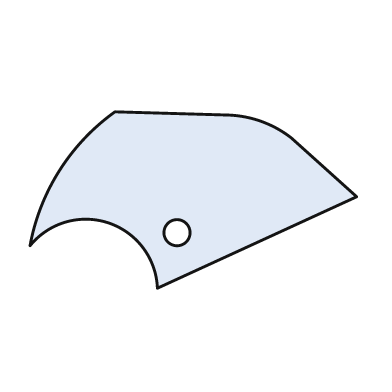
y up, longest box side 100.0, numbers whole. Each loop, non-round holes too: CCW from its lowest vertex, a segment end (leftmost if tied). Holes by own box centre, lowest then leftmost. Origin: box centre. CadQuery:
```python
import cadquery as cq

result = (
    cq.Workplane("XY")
    .moveTo(-11.0, -27.0)
    .lineTo(50.0, 1.0)
    .lineTo(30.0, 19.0)
    .threePointArc((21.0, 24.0), (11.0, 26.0))
    .lineTo(-24.0, 27.0)
    .threePointArc((-41.0, 9.0), (-50.0, -14.0))
    .threePointArc((-26.0, -7.0), (-11.0, -27.0))
    .close()
    .moveTo(-5.0, -10.0)
    .circle(4.0)
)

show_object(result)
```